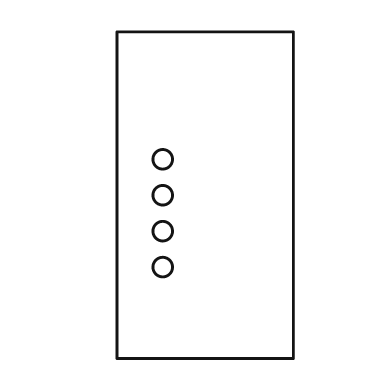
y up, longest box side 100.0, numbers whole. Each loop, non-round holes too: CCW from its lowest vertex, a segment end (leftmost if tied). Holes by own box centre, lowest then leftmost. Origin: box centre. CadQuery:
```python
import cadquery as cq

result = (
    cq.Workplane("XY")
    .moveTo(-27.0, -50.0)
    .lineTo(27.0, -50.0)
    .lineTo(27.0, 50.0)
    .lineTo(-27.0, 50.0)
    .close()
    .moveTo(-13.0, -22.0)
    .circle(3.0)
    .moveTo(-13.0, -11.0)
    .circle(3.0)
    .moveTo(-13.0, 0.0)
    .circle(3.0)
    .moveTo(-13.0, 11.0)
    .circle(3.0)
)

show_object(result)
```